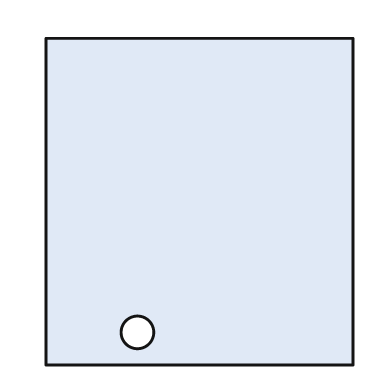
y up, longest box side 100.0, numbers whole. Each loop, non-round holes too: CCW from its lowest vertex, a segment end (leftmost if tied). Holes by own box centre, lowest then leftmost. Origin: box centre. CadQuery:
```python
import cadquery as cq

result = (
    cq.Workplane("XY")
    .moveTo(-47.0, -50.0)
    .lineTo(47.0, -50.0)
    .lineTo(47.0, 50.0)
    .lineTo(-47.0, 50.0)
    .close()
    .moveTo(-19.0, -40.0)
    .circle(5.0)
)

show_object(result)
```